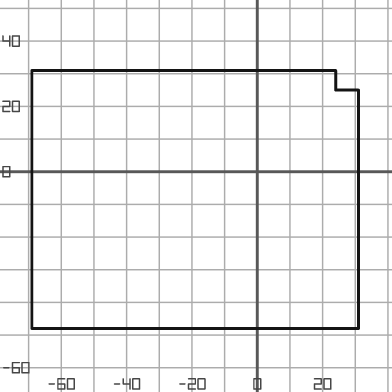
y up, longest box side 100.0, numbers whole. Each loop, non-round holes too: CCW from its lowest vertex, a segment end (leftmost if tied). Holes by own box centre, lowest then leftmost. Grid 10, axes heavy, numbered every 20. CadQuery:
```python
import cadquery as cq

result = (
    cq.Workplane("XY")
    .moveTo(-69.0, -48.0)
    .lineTo(31.0, -48.0)
    .lineTo(31.0, 25.0)
    .lineTo(24.0, 25.0)
    .lineTo(24.0, 31.0)
    .lineTo(-69.0, 31.0)
    .close()
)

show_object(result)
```